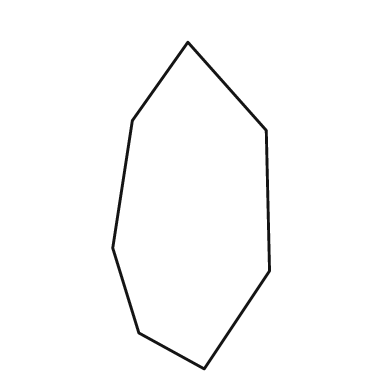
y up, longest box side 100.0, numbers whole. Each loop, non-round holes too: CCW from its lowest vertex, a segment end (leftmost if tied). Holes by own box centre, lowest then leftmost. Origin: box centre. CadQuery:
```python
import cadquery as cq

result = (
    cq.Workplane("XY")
    .moveTo(4.0, -50.0)
    .lineTo(24.0, -20.0)
    .lineTo(23.0, 23.0)
    .lineTo(-1.0, 50.0)
    .lineTo(-18.0, 26.0)
    .lineTo(-24.0, -13.0)
    .lineTo(-16.0, -39.0)
    .close()
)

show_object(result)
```